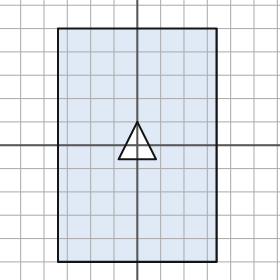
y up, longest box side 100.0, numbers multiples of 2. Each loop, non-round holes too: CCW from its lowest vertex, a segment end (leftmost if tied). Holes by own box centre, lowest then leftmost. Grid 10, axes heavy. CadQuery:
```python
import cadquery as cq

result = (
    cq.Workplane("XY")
    .moveTo(-34.0, -50.0)
    .lineTo(34.0, -50.0)
    .lineTo(34.0, 50.0)
    .lineTo(-34.0, 50.0)
    .close()
    .moveTo(-8.0, -6.0)
    .lineTo(8.0, -6.0)
    .lineTo(0.0, 10.0)
    .close()
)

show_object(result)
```